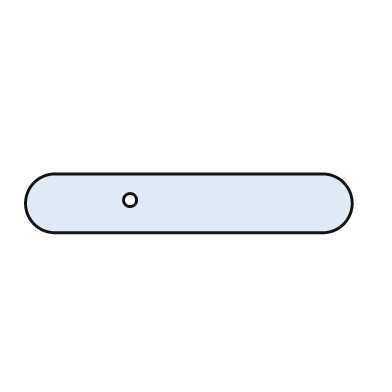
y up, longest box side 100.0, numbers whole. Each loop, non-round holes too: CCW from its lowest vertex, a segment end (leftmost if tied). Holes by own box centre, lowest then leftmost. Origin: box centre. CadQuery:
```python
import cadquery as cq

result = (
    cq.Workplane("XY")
    .moveTo(-41.0, -9.0)
    .lineTo(41.0, -9.0)
    .threePointArc((50.0, 0.0), (41.0, 9.0))
    .lineTo(-41.0, 9.0)
    .threePointArc((-50.0, 0.0), (-41.0, -9.0))
    .close()
    .moveTo(-18.0, 1.0)
    .circle(2.0)
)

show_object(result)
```